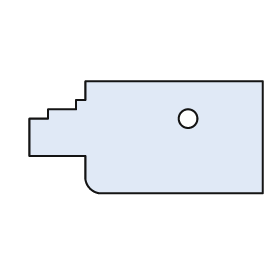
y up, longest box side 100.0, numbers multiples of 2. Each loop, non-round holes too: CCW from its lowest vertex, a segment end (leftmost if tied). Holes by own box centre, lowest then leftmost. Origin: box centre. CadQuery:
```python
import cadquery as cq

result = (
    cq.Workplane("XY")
    .moveTo(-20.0, -24.0)
    .lineTo(50.0, -24.0)
    .lineTo(50.0, 24.0)
    .lineTo(-26.0, 24.0)
    .lineTo(-26.0, 16.0)
    .lineTo(-30.0, 16.0)
    .lineTo(-30.0, 12.0)
    .lineTo(-42.0, 12.0)
    .lineTo(-42.0, 8.0)
    .lineTo(-50.0, 8.0)
    .lineTo(-50.0, -8.0)
    .lineTo(-26.0, -8.0)
    .lineTo(-26.0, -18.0)
    .threePointArc((-24.0, -22.0), (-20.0, -24.0))
    .close()
    .moveTo(18.0, 8.0)
    .circle(4.0)
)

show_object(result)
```